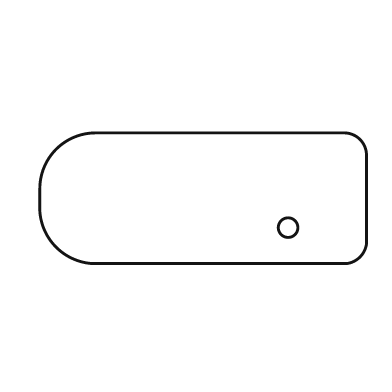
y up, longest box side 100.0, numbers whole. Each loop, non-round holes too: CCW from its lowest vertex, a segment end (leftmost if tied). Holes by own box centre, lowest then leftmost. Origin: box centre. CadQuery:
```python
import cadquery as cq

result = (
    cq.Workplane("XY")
    .moveTo(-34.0, -20.0)
    .lineTo(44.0, -20.0)
    .threePointArc((48.0, -18.0), (50.0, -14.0))
    .lineTo(50.0, 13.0)
    .threePointArc((48.0, 18.0), (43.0, 20.0))
    .lineTo(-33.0, 20.0)
    .threePointArc((-45.0, 15.0), (-50.0, 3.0))
    .lineTo(-50.0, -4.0)
    .threePointArc((-45.0, -15.0), (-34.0, -20.0))
    .close()
    .moveTo(26.0, -9.0)
    .circle(3.0)
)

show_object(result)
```